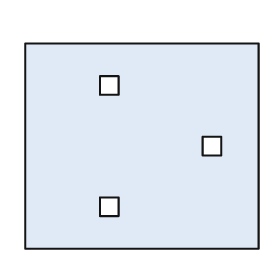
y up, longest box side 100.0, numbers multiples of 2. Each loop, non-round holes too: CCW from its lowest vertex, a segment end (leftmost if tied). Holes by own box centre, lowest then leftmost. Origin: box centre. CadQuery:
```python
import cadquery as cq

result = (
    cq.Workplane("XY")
    .moveTo(-50.0, -44.0)
    .lineTo(50.0, -44.0)
    .lineTo(50.0, 44.0)
    .lineTo(-50.0, 44.0)
    .close()
    .moveTo(-18.0, -30.0)
    .lineTo(-10.0, -30.0)
    .lineTo(-10.0, -22.0)
    .lineTo(-18.0, -22.0)
    .close()
    .moveTo(26.0, -4.0)
    .lineTo(34.0, -4.0)
    .lineTo(34.0, 4.0)
    .lineTo(26.0, 4.0)
    .close()
    .moveTo(-18.0, 22.0)
    .lineTo(-10.0, 22.0)
    .lineTo(-10.0, 30.0)
    .lineTo(-18.0, 30.0)
    .close()
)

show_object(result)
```